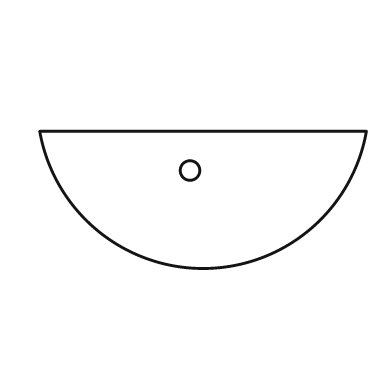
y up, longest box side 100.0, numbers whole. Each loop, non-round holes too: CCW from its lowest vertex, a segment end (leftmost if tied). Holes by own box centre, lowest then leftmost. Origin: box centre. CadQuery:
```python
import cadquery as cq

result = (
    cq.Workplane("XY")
    .moveTo(-50.0, 21.0)
    .threePointArc((0.0, -21.0), (50.0, 21.0))
    .close()
    .moveTo(-4.0, 9.0)
    .circle(3.0)
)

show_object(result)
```